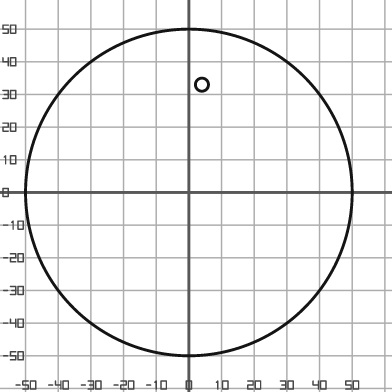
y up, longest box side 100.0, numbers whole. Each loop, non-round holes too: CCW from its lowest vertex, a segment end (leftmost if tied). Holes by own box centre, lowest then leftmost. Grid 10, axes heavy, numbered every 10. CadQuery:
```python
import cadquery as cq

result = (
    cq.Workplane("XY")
    .moveTo(0.0, 0.0)
    .circle(50.0)
    .moveTo(4.0, 33.0)
    .circle(2.0)
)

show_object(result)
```